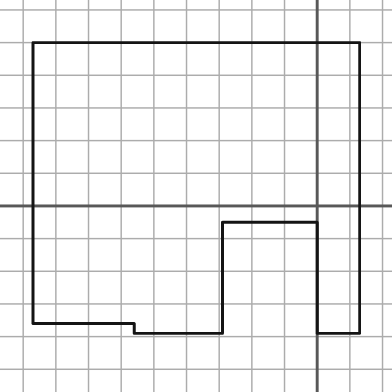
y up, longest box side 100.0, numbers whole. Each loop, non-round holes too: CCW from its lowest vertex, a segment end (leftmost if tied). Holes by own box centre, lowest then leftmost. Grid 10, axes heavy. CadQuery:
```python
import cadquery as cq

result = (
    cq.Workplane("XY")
    .moveTo(-56.0, -39.0)
    .lineTo(-29.0, -39.0)
    .lineTo(-29.0, -5.0)
    .lineTo(0.0, -5.0)
    .lineTo(0.0, -39.0)
    .lineTo(13.0, -39.0)
    .lineTo(13.0, 50.0)
    .lineTo(-87.0, 50.0)
    .lineTo(-87.0, -36.0)
    .lineTo(-56.0, -36.0)
    .close()
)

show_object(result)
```